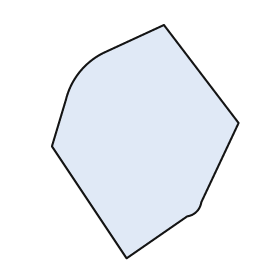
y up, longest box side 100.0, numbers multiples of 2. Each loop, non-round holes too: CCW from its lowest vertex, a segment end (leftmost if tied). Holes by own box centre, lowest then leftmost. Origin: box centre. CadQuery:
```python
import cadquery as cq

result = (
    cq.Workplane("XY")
    .moveTo(-8.0, -50.0)
    .lineTo(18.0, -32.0)
    .threePointArc((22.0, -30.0), (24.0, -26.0))
    .lineTo(40.0, 8.0)
    .lineTo(8.0, 50.0)
    .lineTo(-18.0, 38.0)
    .threePointArc((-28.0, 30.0), (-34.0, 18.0))
    .lineTo(-40.0, -2.0)
    .close()
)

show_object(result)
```